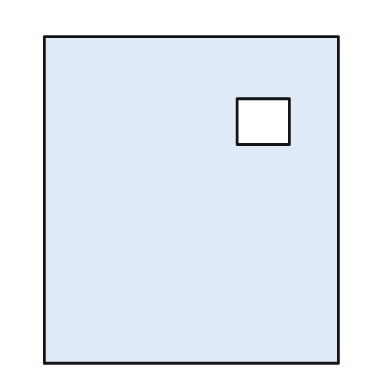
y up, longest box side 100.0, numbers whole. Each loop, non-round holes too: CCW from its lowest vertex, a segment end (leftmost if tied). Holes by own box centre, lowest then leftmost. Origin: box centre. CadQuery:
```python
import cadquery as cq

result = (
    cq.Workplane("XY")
    .moveTo(-45.0, -50.0)
    .lineTo(45.0, -50.0)
    .lineTo(45.0, 50.0)
    .lineTo(-45.0, 50.0)
    .close()
    .moveTo(14.0, 17.0)
    .lineTo(30.0, 17.0)
    .lineTo(30.0, 31.0)
    .lineTo(14.0, 31.0)
    .close()
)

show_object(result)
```